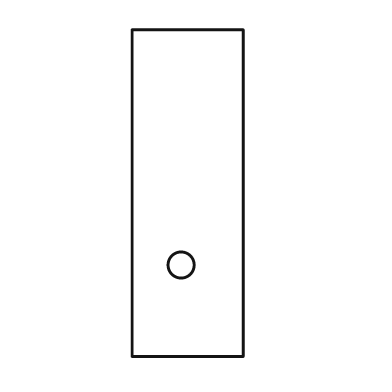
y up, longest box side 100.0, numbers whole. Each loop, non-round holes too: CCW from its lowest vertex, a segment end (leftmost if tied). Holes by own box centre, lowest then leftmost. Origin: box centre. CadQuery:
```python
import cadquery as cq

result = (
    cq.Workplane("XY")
    .moveTo(-17.0, -50.0)
    .lineTo(17.0, -50.0)
    .lineTo(17.0, 50.0)
    .lineTo(-17.0, 50.0)
    .close()
    .moveTo(-2.0, -22.0)
    .circle(4.0)
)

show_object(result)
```